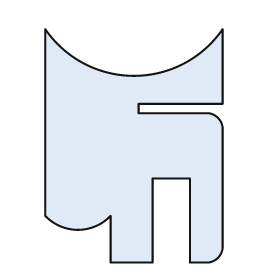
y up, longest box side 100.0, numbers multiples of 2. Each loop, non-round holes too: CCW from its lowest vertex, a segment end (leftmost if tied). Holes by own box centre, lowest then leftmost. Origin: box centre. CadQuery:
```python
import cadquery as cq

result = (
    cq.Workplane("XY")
    .moveTo(-10.0, -50.0)
    .lineTo(8.0, -50.0)
    .lineTo(8.0, -14.0)
    .lineTo(24.0, -14.0)
    .lineTo(24.0, -50.0)
    .lineTo(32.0, -50.0)
    .threePointArc((36.0, -48.0), (38.0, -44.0))
    .lineTo(38.0, 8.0)
    .threePointArc((36.0, 12.0), (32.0, 14.0))
    .lineTo(2.0, 14.0)
    .lineTo(2.0, 18.0)
    .lineTo(38.0, 18.0)
    .lineTo(38.0, 50.0)
    .threePointArc((0.0, 30.0), (-38.0, 50.0))
    .lineTo(-38.0, -30.0)
    .threePointArc((-24.0, -36.0), (-10.0, -30.0))
    .close()
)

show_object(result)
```